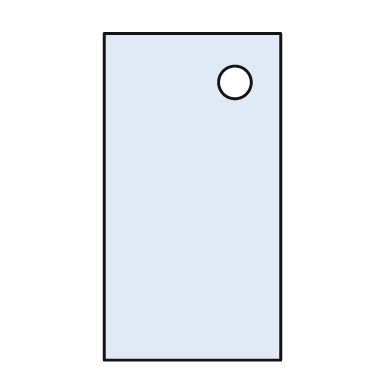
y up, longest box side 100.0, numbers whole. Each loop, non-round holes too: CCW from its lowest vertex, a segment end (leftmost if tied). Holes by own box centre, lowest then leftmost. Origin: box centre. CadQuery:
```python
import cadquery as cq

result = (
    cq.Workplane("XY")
    .moveTo(-27.0, -50.0)
    .lineTo(27.0, -50.0)
    .lineTo(27.0, 50.0)
    .lineTo(-27.0, 50.0)
    .close()
    .moveTo(13.0, 35.0)
    .circle(5.0)
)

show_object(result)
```